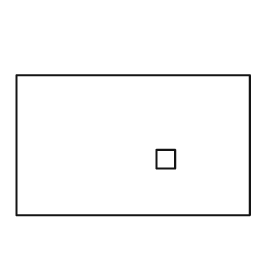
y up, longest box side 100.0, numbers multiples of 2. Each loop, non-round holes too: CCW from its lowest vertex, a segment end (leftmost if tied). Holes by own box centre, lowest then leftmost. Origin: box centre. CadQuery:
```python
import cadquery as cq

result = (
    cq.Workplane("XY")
    .moveTo(-50.0, -30.0)
    .lineTo(50.0, -30.0)
    .lineTo(50.0, 30.0)
    .lineTo(-50.0, 30.0)
    .close()
    .moveTo(10.0, -10.0)
    .lineTo(18.0, -10.0)
    .lineTo(18.0, -2.0)
    .lineTo(10.0, -2.0)
    .close()
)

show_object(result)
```